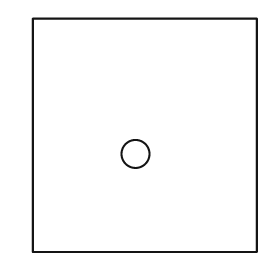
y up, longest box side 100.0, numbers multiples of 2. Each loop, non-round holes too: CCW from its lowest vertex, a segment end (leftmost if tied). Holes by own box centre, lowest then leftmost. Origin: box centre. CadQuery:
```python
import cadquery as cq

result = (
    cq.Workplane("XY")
    .moveTo(-48.0, -50.0)
    .lineTo(48.0, -50.0)
    .lineTo(48.0, 50.0)
    .lineTo(-48.0, 50.0)
    .close()
    .moveTo(-4.0, -8.0)
    .circle(6.0)
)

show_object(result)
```